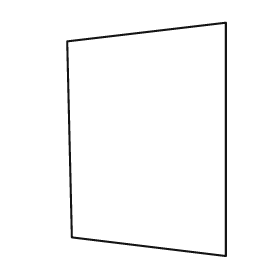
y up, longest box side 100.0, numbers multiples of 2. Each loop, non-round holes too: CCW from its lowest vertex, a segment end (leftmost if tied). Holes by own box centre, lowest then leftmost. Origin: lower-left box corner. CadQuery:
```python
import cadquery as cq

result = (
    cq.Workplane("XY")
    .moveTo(68.0, 0.0)
    .lineTo(68.0, 100.0)
    .lineTo(0.0, 92.0)
    .lineTo(2.0, 8.0)
    .close()
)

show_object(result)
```